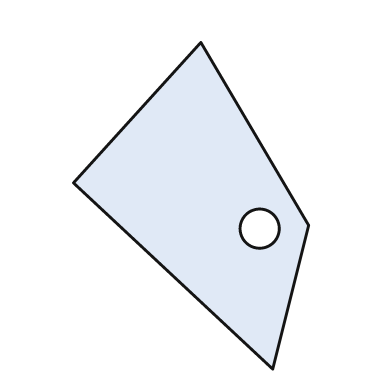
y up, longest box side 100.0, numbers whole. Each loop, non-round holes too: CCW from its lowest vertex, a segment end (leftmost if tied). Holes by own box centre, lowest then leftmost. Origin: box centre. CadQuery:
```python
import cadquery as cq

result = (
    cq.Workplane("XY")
    .moveTo(25.0, -50.0)
    .lineTo(36.0, -6.0)
    .lineTo(3.0, 50.0)
    .lineTo(-36.0, 7.0)
    .close()
    .moveTo(21.0, -7.0)
    .circle(6.0)
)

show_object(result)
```